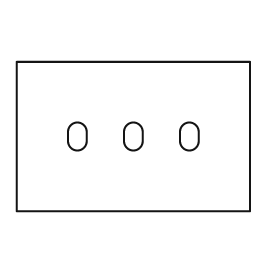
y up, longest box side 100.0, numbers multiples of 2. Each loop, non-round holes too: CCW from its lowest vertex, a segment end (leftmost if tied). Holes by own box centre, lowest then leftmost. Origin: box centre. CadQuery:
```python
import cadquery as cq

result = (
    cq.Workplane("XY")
    .moveTo(-50.0, -32.0)
    .lineTo(50.0, -32.0)
    .lineTo(50.0, 32.0)
    .lineTo(-50.0, 32.0)
    .close()
    .moveTo(-28.0, -2.0)
    .threePointArc((-24.0, -6.0), (-20.0, -2.0))
    .lineTo(-20.0, 2.0)
    .threePointArc((-24.0, 6.0), (-28.0, 2.0))
    .close()
    .moveTo(-4.0, -2.0)
    .threePointArc((0.0, -6.0), (4.0, -2.0))
    .lineTo(4.0, 2.0)
    .threePointArc((0.0, 6.0), (-4.0, 2.0))
    .close()
    .moveTo(20.0, -2.0)
    .threePointArc((24.0, -6.0), (28.0, -2.0))
    .lineTo(28.0, 2.0)
    .threePointArc((24.0, 6.0), (20.0, 2.0))
    .close()
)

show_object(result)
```